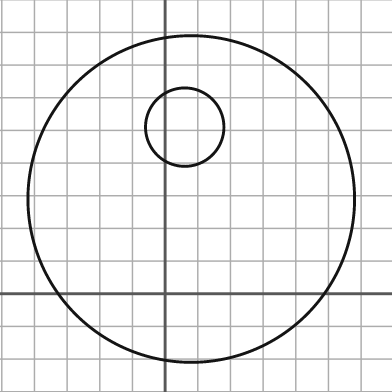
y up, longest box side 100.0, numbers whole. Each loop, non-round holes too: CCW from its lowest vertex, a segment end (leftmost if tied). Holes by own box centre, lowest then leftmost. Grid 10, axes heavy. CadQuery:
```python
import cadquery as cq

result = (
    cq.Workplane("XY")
    .moveTo(8.0, 29.0)
    .circle(50.0)
    .moveTo(6.0, 51.0)
    .circle(12.0)
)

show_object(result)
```